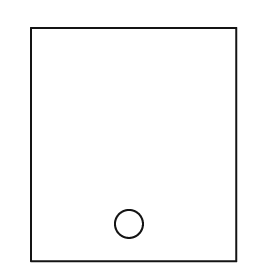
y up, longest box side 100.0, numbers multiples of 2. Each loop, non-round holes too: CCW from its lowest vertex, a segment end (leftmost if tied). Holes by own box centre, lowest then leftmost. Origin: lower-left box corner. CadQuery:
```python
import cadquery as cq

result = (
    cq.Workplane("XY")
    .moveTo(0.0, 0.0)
    .lineTo(88.0, 0.0)
    .lineTo(88.0, 100.0)
    .lineTo(0.0, 100.0)
    .close()
    .moveTo(42.0, 16.0)
    .circle(6.0)
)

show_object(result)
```